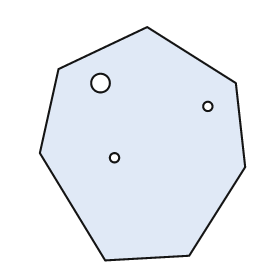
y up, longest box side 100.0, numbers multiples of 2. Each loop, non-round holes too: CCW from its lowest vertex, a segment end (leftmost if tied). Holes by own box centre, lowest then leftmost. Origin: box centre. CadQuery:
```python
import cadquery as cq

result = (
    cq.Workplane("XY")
    .moveTo(-16.0, -50.0)
    .lineTo(20.0, -48.0)
    .lineTo(44.0, -10.0)
    .lineTo(40.0, 26.0)
    .lineTo(2.0, 50.0)
    .lineTo(-36.0, 32.0)
    .lineTo(-44.0, -4.0)
    .close()
    .moveTo(-12.0, -6.0)
    .circle(2.0)
    .moveTo(28.0, 16.0)
    .circle(2.0)
    .moveTo(-18.0, 26.0)
    .circle(4.0)
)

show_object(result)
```